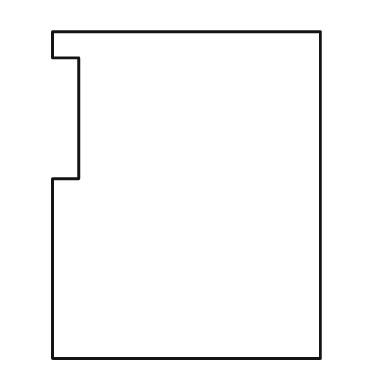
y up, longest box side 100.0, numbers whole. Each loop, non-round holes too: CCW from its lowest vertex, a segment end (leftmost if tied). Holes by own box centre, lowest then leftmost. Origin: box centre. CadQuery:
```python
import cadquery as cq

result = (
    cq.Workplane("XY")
    .moveTo(-41.0, -50.0)
    .lineTo(41.0, -50.0)
    .lineTo(41.0, 50.0)
    .lineTo(-41.0, 50.0)
    .lineTo(-41.0, 42.0)
    .lineTo(-33.0, 42.0)
    .lineTo(-33.0, 5.0)
    .lineTo(-41.0, 5.0)
    .close()
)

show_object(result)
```